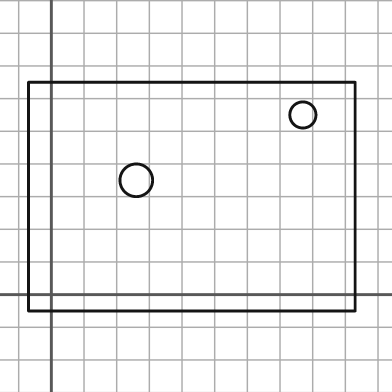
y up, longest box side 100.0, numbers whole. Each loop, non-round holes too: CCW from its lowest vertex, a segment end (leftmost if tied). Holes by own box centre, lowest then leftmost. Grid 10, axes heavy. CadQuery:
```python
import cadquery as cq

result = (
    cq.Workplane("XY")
    .moveTo(-7.0, -5.0)
    .lineTo(93.0, -5.0)
    .lineTo(93.0, 65.0)
    .lineTo(-7.0, 65.0)
    .close()
    .moveTo(26.0, 35.0)
    .circle(5.0)
    .moveTo(77.0, 55.0)
    .circle(4.0)
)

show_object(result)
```